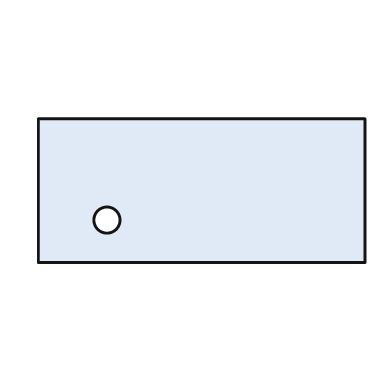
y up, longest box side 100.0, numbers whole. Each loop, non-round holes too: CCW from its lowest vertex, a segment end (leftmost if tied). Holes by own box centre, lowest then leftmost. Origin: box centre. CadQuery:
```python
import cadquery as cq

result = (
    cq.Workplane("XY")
    .moveTo(-50.0, -22.0)
    .lineTo(50.0, -22.0)
    .lineTo(50.0, 22.0)
    .lineTo(-50.0, 22.0)
    .close()
    .moveTo(-29.0, -9.0)
    .circle(4.0)
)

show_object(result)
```